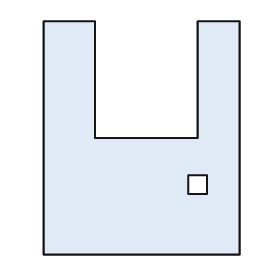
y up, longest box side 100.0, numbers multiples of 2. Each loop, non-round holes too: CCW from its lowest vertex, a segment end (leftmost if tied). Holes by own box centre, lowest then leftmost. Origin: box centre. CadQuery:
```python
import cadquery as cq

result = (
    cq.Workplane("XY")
    .moveTo(-42.0, -50.0)
    .lineTo(42.0, -50.0)
    .lineTo(42.0, 50.0)
    .lineTo(24.0, 50.0)
    .lineTo(24.0, 0.0)
    .lineTo(-20.0, 0.0)
    .lineTo(-20.0, 50.0)
    .lineTo(-42.0, 50.0)
    .close()
    .moveTo(20.0, -24.0)
    .lineTo(28.0, -24.0)
    .lineTo(28.0, -16.0)
    .lineTo(20.0, -16.0)
    .close()
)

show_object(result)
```